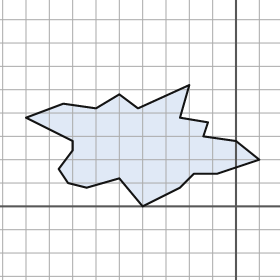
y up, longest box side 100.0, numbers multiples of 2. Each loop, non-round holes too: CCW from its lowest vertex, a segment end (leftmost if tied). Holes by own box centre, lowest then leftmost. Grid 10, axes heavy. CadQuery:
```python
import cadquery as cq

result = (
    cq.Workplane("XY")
    .moveTo(-40.0, 0.0)
    .lineTo(-24.0, 8.0)
    .lineTo(-18.0, 14.0)
    .lineTo(-8.0, 14.0)
    .lineTo(10.0, 20.0)
    .lineTo(0.0, 28.0)
    .lineTo(-14.0, 30.0)
    .lineTo(-12.0, 36.0)
    .lineTo(-24.0, 38.0)
    .lineTo(-20.0, 52.0)
    .lineTo(-42.0, 42.0)
    .lineTo(-50.0, 48.0)
    .lineTo(-60.0, 42.0)
    .lineTo(-74.0, 44.0)
    .lineTo(-90.0, 38.0)
    .lineTo(-70.0, 28.0)
    .lineTo(-70.0, 24.0)
    .lineTo(-76.0, 16.0)
    .lineTo(-72.0, 10.0)
    .lineTo(-64.0, 8.0)
    .lineTo(-50.0, 12.0)
    .close()
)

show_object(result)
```